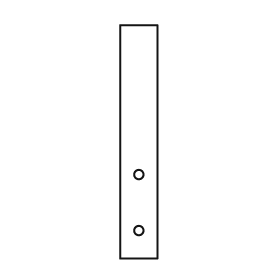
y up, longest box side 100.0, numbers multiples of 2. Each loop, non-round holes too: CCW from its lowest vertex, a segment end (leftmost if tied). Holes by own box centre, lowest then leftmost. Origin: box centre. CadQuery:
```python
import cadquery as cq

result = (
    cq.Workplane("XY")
    .moveTo(-8.0, -50.0)
    .lineTo(8.0, -50.0)
    .lineTo(8.0, 50.0)
    .lineTo(-8.0, 50.0)
    .close()
    .moveTo(0.0, -38.0)
    .circle(2.0)
    .moveTo(0.0, -14.0)
    .circle(2.0)
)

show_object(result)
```